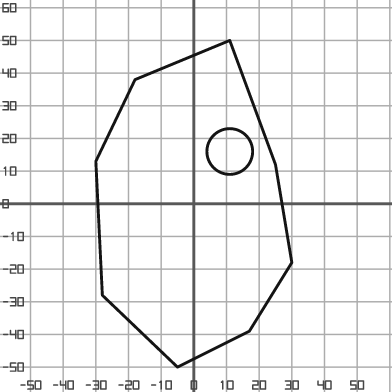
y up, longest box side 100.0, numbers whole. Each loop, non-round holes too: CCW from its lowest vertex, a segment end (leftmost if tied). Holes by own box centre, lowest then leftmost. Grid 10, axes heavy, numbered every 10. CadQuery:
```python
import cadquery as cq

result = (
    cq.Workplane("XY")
    .moveTo(-5.0, -50.0)
    .lineTo(17.0, -39.0)
    .lineTo(30.0, -18.0)
    .lineTo(25.0, 12.0)
    .lineTo(11.0, 50.0)
    .lineTo(-18.0, 38.0)
    .lineTo(-30.0, 13.0)
    .lineTo(-28.0, -28.0)
    .close()
    .moveTo(11.0, 16.0)
    .circle(7.0)
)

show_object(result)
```